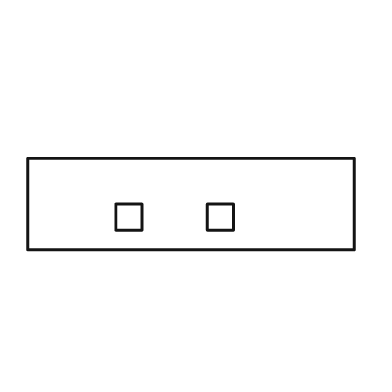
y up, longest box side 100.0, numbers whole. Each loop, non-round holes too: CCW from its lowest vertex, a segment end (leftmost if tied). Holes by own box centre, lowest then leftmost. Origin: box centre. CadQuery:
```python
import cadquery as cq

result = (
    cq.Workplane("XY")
    .moveTo(-50.0, -14.0)
    .lineTo(50.0, -14.0)
    .lineTo(50.0, 14.0)
    .lineTo(-50.0, 14.0)
    .close()
    .moveTo(-23.0, -8.0)
    .lineTo(-15.0, -8.0)
    .lineTo(-15.0, 0.0)
    .lineTo(-23.0, 0.0)
    .close()
    .moveTo(5.0, -8.0)
    .lineTo(13.0, -8.0)
    .lineTo(13.0, 0.0)
    .lineTo(5.0, 0.0)
    .close()
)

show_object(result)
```